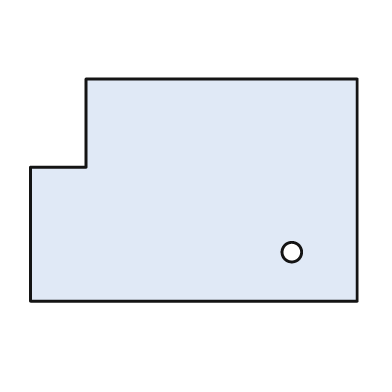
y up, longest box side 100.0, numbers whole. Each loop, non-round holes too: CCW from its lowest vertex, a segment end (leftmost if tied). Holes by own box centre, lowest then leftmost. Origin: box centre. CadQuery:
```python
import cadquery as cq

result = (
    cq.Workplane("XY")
    .moveTo(-50.0, -34.0)
    .lineTo(50.0, -34.0)
    .lineTo(50.0, 34.0)
    .lineTo(-33.0, 34.0)
    .lineTo(-33.0, 7.0)
    .lineTo(-50.0, 7.0)
    .close()
    .moveTo(30.0, -19.0)
    .circle(3.0)
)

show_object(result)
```